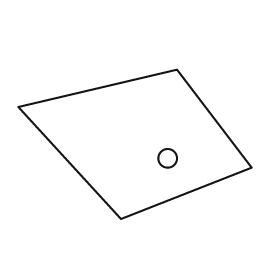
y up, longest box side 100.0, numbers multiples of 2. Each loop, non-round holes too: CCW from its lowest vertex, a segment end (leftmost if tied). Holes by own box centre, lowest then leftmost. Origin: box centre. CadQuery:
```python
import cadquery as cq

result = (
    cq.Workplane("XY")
    .moveTo(-6.0, -32.0)
    .lineTo(50.0, -10.0)
    .lineTo(18.0, 32.0)
    .lineTo(-50.0, 16.0)
    .close()
    .moveTo(14.0, -6.0)
    .circle(4.0)
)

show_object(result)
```